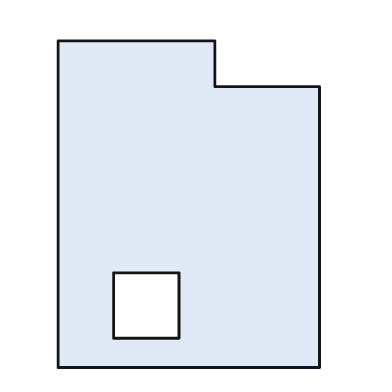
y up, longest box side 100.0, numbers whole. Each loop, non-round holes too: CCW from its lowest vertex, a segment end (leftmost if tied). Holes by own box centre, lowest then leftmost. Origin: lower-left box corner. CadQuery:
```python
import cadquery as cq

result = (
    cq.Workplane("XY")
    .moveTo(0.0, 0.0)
    .lineTo(80.0, 0.0)
    .lineTo(80.0, 86.0)
    .lineTo(48.0, 86.0)
    .lineTo(48.0, 100.0)
    .lineTo(0.0, 100.0)
    .close()
    .moveTo(17.0, 9.0)
    .lineTo(37.0, 9.0)
    .lineTo(37.0, 29.0)
    .lineTo(17.0, 29.0)
    .close()
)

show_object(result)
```